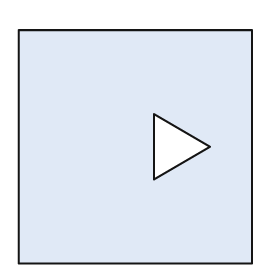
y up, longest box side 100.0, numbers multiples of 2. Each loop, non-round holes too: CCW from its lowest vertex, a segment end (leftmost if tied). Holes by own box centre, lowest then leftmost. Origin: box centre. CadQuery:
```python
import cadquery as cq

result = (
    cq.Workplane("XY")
    .moveTo(-50.0, -50.0)
    .lineTo(50.0, -50.0)
    .lineTo(50.0, 50.0)
    .lineTo(-50.0, 50.0)
    .close()
    .moveTo(8.0, -14.0)
    .lineTo(32.0, 0.0)
    .lineTo(8.0, 14.0)
    .close()
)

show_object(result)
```